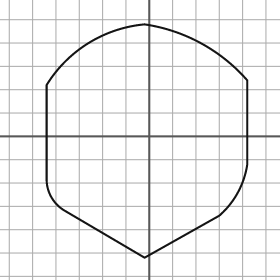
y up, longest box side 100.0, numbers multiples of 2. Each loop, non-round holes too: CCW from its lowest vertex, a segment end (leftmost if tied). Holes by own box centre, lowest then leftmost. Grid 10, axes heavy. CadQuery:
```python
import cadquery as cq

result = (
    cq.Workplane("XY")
    .moveTo(-2.0, -52.0)
    .lineTo(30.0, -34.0)
    .threePointArc((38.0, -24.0), (42.0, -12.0))
    .lineTo(42.0, 24.0)
    .threePointArc((22.0, 40.0), (-2.0, 48.0))
    .threePointArc((-26.0, 40.0), (-44.0, 22.0))
    .lineTo(-44.0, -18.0)
    .threePointArc((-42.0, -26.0), (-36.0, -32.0))
    .close()
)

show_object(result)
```